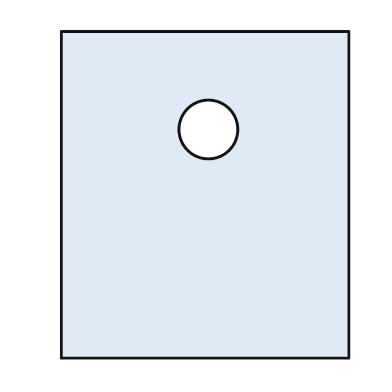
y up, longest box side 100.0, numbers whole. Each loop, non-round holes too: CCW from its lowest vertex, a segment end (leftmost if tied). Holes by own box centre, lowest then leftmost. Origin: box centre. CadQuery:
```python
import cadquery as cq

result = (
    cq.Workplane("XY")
    .moveTo(-44.0, -50.0)
    .lineTo(44.0, -50.0)
    .lineTo(44.0, 50.0)
    .lineTo(-44.0, 50.0)
    .close()
    .moveTo(1.0, 20.0)
    .circle(9.0)
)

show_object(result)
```